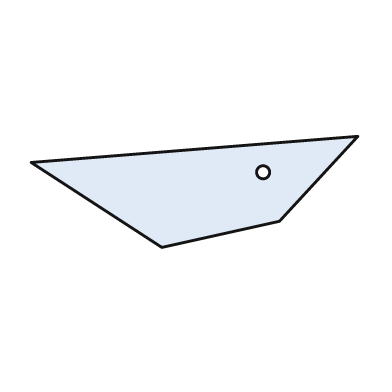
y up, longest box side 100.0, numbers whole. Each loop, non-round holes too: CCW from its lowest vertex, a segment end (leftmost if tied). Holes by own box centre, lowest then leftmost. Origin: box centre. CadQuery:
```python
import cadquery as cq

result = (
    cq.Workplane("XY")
    .moveTo(-10.0, -17.0)
    .lineTo(26.0, -9.0)
    .lineTo(50.0, 17.0)
    .lineTo(-50.0, 9.0)
    .close()
    .moveTo(21.0, 6.0)
    .circle(2.0)
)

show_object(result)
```